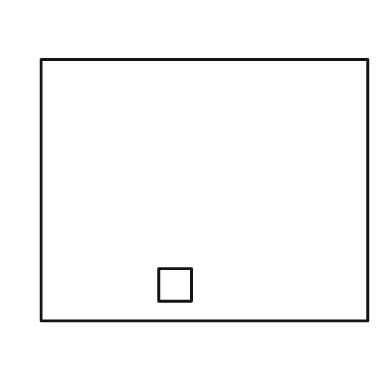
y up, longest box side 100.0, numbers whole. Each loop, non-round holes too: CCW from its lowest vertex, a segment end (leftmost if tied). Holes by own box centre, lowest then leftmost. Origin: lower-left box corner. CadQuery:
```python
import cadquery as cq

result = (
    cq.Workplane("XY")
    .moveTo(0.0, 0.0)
    .lineTo(100.0, 0.0)
    .lineTo(100.0, 80.0)
    .lineTo(0.0, 80.0)
    .close()
    .moveTo(36.0, 6.0)
    .lineTo(46.0, 6.0)
    .lineTo(46.0, 16.0)
    .lineTo(36.0, 16.0)
    .close()
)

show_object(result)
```